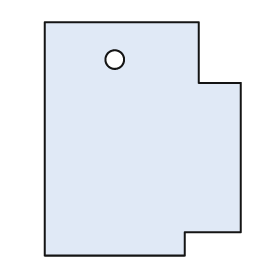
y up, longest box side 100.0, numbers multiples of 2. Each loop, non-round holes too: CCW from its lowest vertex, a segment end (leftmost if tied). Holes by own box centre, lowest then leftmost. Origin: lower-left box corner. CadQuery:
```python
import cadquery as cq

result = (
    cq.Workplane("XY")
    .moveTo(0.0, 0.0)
    .lineTo(60.0, 0.0)
    .lineTo(60.0, 10.0)
    .lineTo(84.0, 10.0)
    .lineTo(84.0, 74.0)
    .lineTo(66.0, 74.0)
    .lineTo(66.0, 100.0)
    .lineTo(0.0, 100.0)
    .close()
    .moveTo(30.0, 84.0)
    .circle(4.0)
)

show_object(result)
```